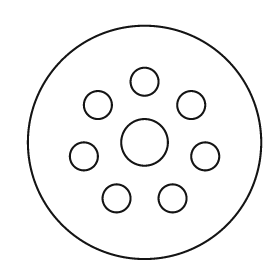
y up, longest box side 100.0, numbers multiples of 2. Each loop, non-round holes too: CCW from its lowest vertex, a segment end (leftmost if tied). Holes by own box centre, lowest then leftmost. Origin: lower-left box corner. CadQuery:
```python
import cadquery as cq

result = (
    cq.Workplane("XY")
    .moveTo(50.0, 50.0)
    .circle(50.0)
    .moveTo(38.0, 26.0)
    .circle(6.0)
    .moveTo(62.0, 26.0)
    .circle(6.0)
    .moveTo(24.0, 44.0)
    .circle(6.0)
    .moveTo(76.0, 44.0)
    .circle(6.0)
    .moveTo(50.0, 50.0)
    .circle(10.0)
    .moveTo(30.0, 66.0)
    .circle(6.0)
    .moveTo(70.0, 66.0)
    .circle(6.0)
    .moveTo(50.0, 76.0)
    .circle(6.0)
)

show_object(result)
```